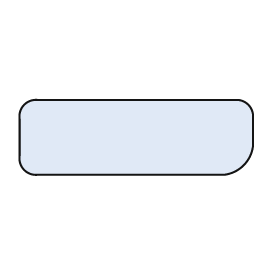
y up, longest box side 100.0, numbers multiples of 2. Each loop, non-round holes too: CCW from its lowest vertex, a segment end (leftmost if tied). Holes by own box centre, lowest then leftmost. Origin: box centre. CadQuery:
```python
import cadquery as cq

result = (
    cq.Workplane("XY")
    .moveTo(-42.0, -16.0)
    .lineTo(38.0, -16.0)
    .threePointArc((46.0, -12.0), (50.0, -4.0))
    .lineTo(50.0, 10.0)
    .threePointArc((48.0, 14.0), (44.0, 16.0))
    .lineTo(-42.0, 16.0)
    .threePointArc((-48.0, 14.0), (-50.0, 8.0))
    .lineTo(-50.0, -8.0)
    .threePointArc((-48.0, -14.0), (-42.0, -16.0))
    .close()
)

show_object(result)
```